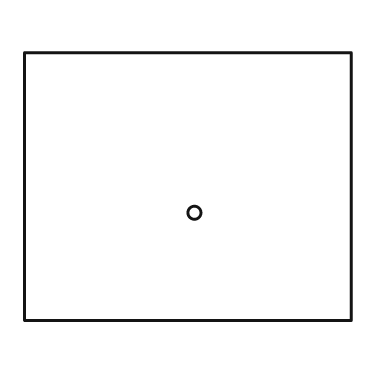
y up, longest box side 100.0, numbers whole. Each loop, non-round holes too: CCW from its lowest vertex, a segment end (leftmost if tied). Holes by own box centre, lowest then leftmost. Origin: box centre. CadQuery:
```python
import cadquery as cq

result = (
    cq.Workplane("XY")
    .moveTo(-50.0, -41.0)
    .lineTo(50.0, -41.0)
    .lineTo(50.0, 41.0)
    .lineTo(-50.0, 41.0)
    .close()
    .moveTo(2.0, -8.0)
    .circle(2.0)
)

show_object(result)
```